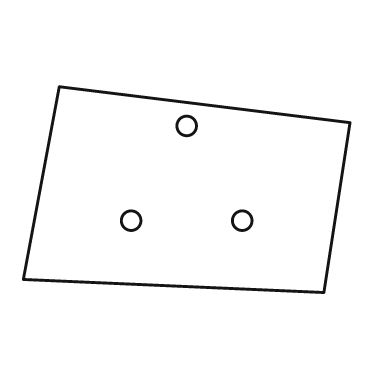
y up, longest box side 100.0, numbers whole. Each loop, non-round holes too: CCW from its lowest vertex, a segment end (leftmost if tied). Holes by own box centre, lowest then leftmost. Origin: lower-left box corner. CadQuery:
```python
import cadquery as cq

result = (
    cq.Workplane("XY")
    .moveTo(92.0, 0.0)
    .lineTo(100.0, 52.0)
    .lineTo(11.0, 63.0)
    .lineTo(0.0, 4.0)
    .close()
    .moveTo(33.0, 22.0)
    .circle(3.0)
    .moveTo(67.0, 22.0)
    .circle(3.0)
    .moveTo(50.0, 51.0)
    .circle(3.0)
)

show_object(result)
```